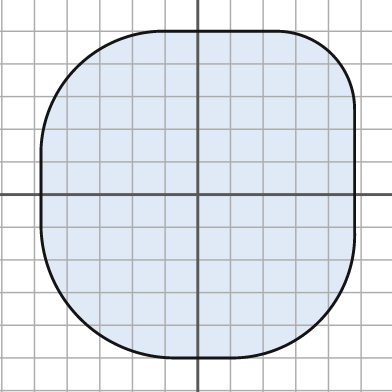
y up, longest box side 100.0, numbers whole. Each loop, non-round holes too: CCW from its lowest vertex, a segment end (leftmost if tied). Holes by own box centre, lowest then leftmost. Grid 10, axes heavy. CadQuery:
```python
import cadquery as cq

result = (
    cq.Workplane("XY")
    .moveTo(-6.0, -50.0)
    .lineTo(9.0, -50.0)
    .threePointArc((37.0, -39.0), (48.0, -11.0))
    .lineTo(48.0, 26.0)
    .threePointArc((41.0, 43.0), (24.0, 50.0))
    .lineTo(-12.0, 50.0)
    .threePointArc((-37.0, 39.0), (-48.0, 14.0))
    .lineTo(-48.0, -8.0)
    .threePointArc((-36.0, -38.0), (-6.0, -50.0))
    .close()
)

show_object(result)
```